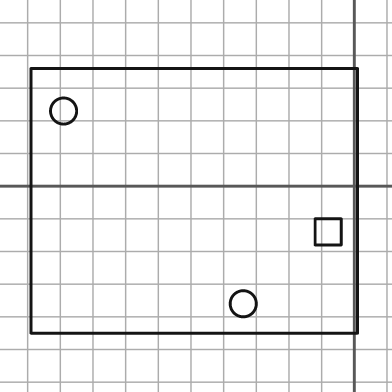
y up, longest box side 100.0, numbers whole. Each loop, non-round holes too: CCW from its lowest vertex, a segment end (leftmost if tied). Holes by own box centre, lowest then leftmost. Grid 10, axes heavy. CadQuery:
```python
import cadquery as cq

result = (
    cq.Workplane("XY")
    .moveTo(-99.0, -45.0)
    .lineTo(1.0, -45.0)
    .lineTo(1.0, 36.0)
    .lineTo(-99.0, 36.0)
    .close()
    .moveTo(-34.0, -36.0)
    .circle(4.0)
    .moveTo(-12.0, -18.0)
    .lineTo(-4.0, -18.0)
    .lineTo(-4.0, -10.0)
    .lineTo(-12.0, -10.0)
    .close()
    .moveTo(-89.0, 23.0)
    .circle(4.0)
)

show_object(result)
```